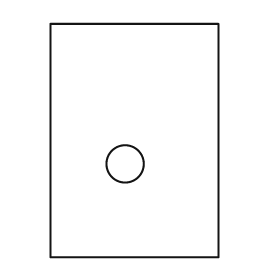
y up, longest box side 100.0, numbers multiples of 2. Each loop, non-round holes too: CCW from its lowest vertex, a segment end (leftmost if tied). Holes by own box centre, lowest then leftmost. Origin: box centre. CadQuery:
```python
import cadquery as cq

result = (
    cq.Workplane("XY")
    .moveTo(-36.0, -50.0)
    .lineTo(36.0, -50.0)
    .lineTo(36.0, 50.0)
    .lineTo(-36.0, 50.0)
    .close()
    .moveTo(-4.0, -10.0)
    .circle(8.0)
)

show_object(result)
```